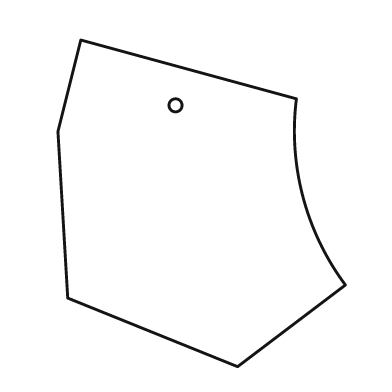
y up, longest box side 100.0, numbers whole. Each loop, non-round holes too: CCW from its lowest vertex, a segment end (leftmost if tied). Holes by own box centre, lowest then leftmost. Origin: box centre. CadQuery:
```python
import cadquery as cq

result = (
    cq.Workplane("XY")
    .moveTo(11.0, -50.0)
    .lineTo(44.0, -25.0)
    .threePointArc((31.0, 2.0), (29.0, 32.0))
    .lineTo(-37.0, 50.0)
    .lineTo(-44.0, 22.0)
    .lineTo(-41.0, -29.0)
    .close()
    .moveTo(-8.0, 30.0)
    .circle(2.0)
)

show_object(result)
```